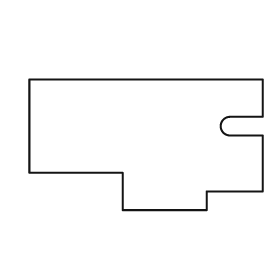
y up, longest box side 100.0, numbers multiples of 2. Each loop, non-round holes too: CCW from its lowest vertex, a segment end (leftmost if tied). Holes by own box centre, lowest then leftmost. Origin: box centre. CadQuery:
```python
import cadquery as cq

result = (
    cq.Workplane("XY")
    .moveTo(-10.0, -28.0)
    .lineTo(26.0, -28.0)
    .lineTo(26.0, -20.0)
    .lineTo(50.0, -20.0)
    .lineTo(50.0, 4.0)
    .lineTo(36.0, 4.0)
    .threePointArc((32.0, 8.0), (36.0, 12.0))
    .lineTo(50.0, 12.0)
    .lineTo(50.0, 28.0)
    .lineTo(-50.0, 28.0)
    .lineTo(-50.0, -12.0)
    .lineTo(-10.0, -12.0)
    .close()
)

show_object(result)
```